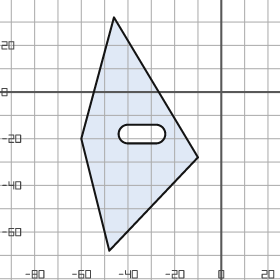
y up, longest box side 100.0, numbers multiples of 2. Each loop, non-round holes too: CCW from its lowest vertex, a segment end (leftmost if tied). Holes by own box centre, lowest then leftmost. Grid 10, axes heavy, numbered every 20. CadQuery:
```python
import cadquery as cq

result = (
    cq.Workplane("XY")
    .moveTo(-48.0, -68.0)
    .lineTo(-10.0, -28.0)
    .lineTo(-46.0, 32.0)
    .lineTo(-60.0, -20.0)
    .close()
    .moveTo(-40.0, -22.0)
    .lineTo(-28.0, -22.0)
    .threePointArc((-24.0, -18.0), (-28.0, -14.0))
    .lineTo(-40.0, -14.0)
    .threePointArc((-44.0, -18.0), (-40.0, -22.0))
    .close()
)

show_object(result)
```